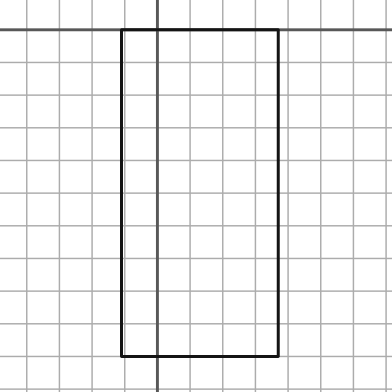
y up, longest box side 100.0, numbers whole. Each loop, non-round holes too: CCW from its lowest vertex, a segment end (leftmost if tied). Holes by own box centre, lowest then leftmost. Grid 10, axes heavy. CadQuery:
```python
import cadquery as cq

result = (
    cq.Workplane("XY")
    .moveTo(-11.0, -100.0)
    .lineTo(37.0, -100.0)
    .lineTo(37.0, 0.0)
    .lineTo(-11.0, 0.0)
    .close()
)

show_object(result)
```